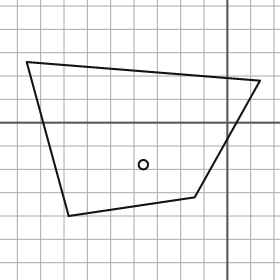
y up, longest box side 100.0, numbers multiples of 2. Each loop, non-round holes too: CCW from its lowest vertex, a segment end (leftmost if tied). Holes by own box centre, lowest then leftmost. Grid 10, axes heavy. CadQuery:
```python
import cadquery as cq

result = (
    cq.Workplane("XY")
    .moveTo(-68.0, -40.0)
    .lineTo(-14.0, -32.0)
    .lineTo(14.0, 18.0)
    .lineTo(-86.0, 26.0)
    .close()
    .moveTo(-36.0, -18.0)
    .circle(2.0)
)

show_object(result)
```